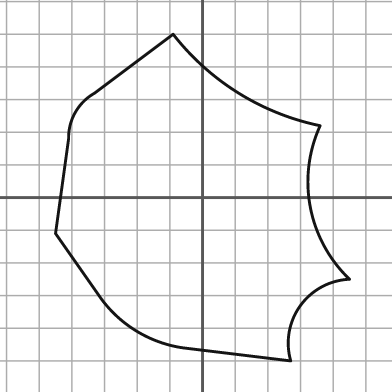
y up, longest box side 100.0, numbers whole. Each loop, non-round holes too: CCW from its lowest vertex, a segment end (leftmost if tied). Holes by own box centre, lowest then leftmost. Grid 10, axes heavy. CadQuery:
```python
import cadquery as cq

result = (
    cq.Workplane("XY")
    .moveTo(27.0, -50.0)
    .threePointArc((30.0, -33.0), (45.0, -25.0))
    .threePointArc((33.0, -3.0), (36.0, 22.0))
    .threePointArc((11.0, 32.0), (-9.0, 50.0))
    .lineTo(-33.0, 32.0)
    .threePointArc((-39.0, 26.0), (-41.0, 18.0))
    .lineTo(-45.0, -11.0)
    .lineTo(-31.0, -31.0)
    .threePointArc((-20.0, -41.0), (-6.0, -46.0))
    .close()
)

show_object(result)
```